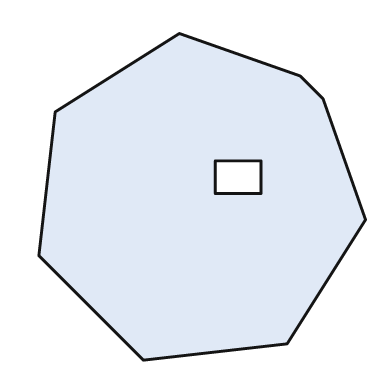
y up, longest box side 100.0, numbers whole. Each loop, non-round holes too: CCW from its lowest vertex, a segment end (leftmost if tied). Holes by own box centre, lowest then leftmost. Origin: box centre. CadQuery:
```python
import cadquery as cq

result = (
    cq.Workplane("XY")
    .moveTo(-18.0, -50.0)
    .lineTo(26.0, -45.0)
    .lineTo(50.0, -7.0)
    .lineTo(37.0, 30.0)
    .lineTo(30.0, 37.0)
    .lineTo(-7.0, 50.0)
    .lineTo(-45.0, 26.0)
    .lineTo(-50.0, -18.0)
    .close()
    .moveTo(4.0, 1.0)
    .lineTo(18.0, 1.0)
    .lineTo(18.0, 11.0)
    .lineTo(4.0, 11.0)
    .close()
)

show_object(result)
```